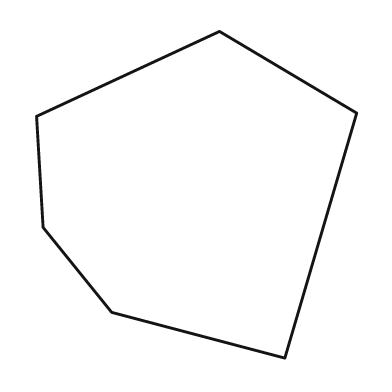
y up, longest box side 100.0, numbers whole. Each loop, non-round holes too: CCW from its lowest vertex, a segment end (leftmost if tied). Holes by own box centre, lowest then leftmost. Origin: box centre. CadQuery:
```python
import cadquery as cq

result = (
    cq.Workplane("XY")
    .moveTo(27.0, -50.0)
    .lineTo(49.0, 25.0)
    .lineTo(7.0, 50.0)
    .lineTo(-49.0, 24.0)
    .lineTo(-47.0, -10.0)
    .lineTo(-26.0, -36.0)
    .close()
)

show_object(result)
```